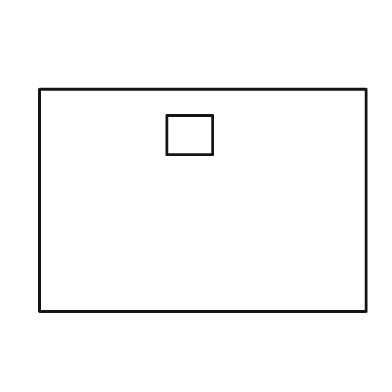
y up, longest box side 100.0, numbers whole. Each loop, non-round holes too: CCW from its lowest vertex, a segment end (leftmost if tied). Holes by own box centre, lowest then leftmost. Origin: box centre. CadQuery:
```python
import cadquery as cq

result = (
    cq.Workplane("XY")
    .moveTo(-50.0, -34.0)
    .lineTo(50.0, -34.0)
    .lineTo(50.0, 34.0)
    .lineTo(-50.0, 34.0)
    .close()
    .moveTo(-11.0, 14.0)
    .lineTo(3.0, 14.0)
    .lineTo(3.0, 26.0)
    .lineTo(-11.0, 26.0)
    .close()
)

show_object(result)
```